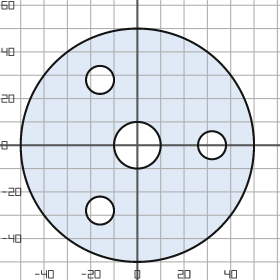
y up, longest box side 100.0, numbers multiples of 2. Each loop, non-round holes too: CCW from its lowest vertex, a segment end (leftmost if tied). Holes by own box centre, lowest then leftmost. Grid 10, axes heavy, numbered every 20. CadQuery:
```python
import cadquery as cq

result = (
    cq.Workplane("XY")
    .moveTo(0.0, 0.0)
    .circle(50.0)
    .moveTo(-16.0, -28.0)
    .circle(6.0)
    .moveTo(0.0, 0.0)
    .circle(10.0)
    .moveTo(32.0, 0.0)
    .circle(6.0)
    .moveTo(-16.0, 28.0)
    .circle(6.0)
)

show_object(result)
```